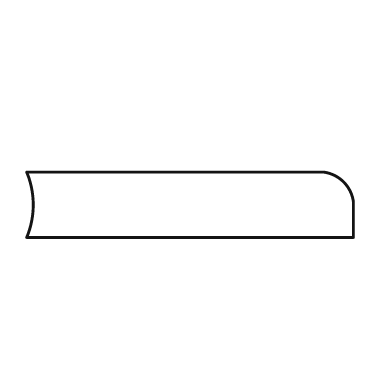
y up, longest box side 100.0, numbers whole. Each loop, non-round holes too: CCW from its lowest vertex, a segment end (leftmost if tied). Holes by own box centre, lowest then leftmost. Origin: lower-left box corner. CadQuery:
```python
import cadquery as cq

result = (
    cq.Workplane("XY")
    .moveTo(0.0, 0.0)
    .lineTo(100.0, 0.0)
    .lineTo(100.0, 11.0)
    .threePointArc((97.0, 17.0), (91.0, 20.0))
    .lineTo(0.0, 20.0)
    .threePointArc((2.0, 10.0), (0.0, 0.0))
    .close()
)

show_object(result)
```